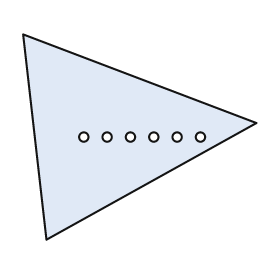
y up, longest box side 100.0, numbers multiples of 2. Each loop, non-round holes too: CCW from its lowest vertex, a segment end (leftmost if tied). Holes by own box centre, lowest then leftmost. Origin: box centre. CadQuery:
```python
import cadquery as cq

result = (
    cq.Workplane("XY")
    .moveTo(-40.0, -44.0)
    .lineTo(50.0, 6.0)
    .lineTo(-50.0, 44.0)
    .close()
    .moveTo(-24.0, 0.0)
    .circle(2.0)
    .moveTo(-14.0, 0.0)
    .circle(2.0)
    .moveTo(-4.0, 0.0)
    .circle(2.0)
    .moveTo(6.0, 0.0)
    .circle(2.0)
    .moveTo(16.0, 0.0)
    .circle(2.0)
    .moveTo(26.0, 0.0)
    .circle(2.0)
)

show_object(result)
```